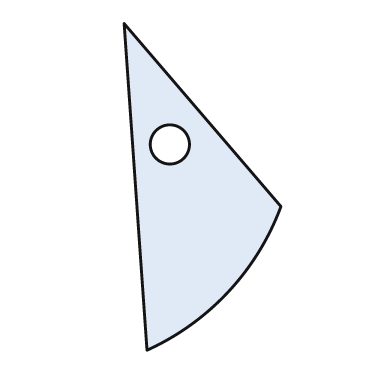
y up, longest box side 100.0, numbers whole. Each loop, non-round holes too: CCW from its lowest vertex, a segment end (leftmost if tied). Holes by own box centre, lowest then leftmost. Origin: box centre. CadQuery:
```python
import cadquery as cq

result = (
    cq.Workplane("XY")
    .moveTo(-17.0, -50.0)
    .threePointArc((8.0, -32.0), (24.0, -6.0))
    .lineTo(-24.0, 50.0)
    .close()
    .moveTo(-10.0, 13.0)
    .circle(6.0)
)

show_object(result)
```